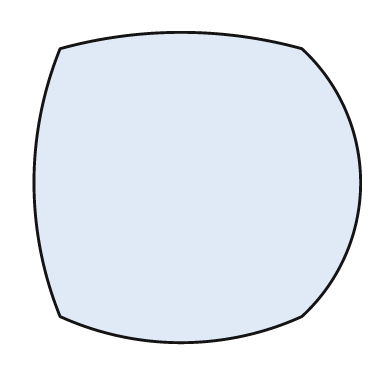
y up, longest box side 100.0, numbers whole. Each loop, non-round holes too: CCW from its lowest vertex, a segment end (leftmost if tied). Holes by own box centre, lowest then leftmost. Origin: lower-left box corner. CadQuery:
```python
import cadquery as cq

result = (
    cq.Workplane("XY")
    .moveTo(8.0, 8.0)
    .threePointArc((45.0, 0.0), (82.0, 8.0))
    .threePointArc((100.0, 49.0), (82.0, 90.0))
    .threePointArc((45.0, 95.0), (8.0, 90.0))
    .threePointArc((0.0, 49.0), (8.0, 8.0))
    .close()
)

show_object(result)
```